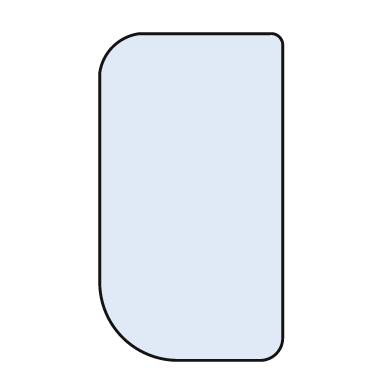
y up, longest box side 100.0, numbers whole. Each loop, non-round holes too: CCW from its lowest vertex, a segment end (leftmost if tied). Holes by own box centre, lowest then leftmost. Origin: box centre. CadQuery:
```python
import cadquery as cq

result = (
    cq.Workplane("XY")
    .moveTo(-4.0, -50.0)
    .lineTo(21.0, -50.0)
    .threePointArc((26.0, -48.0), (28.0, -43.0))
    .lineTo(28.0, 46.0)
    .threePointArc((27.0, 49.0), (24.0, 50.0))
    .lineTo(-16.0, 50.0)
    .threePointArc((-24.0, 46.0), (-28.0, 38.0))
    .lineTo(-28.0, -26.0)
    .threePointArc((-21.0, -43.0), (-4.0, -50.0))
    .close()
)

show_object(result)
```